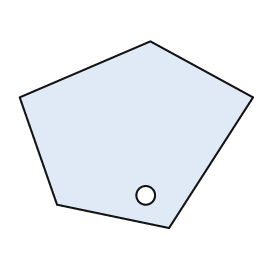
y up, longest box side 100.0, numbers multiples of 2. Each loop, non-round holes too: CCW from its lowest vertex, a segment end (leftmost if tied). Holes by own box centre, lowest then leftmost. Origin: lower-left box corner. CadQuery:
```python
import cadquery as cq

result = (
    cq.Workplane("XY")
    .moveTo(64.0, 0.0)
    .lineTo(100.0, 56.0)
    .lineTo(56.0, 80.0)
    .lineTo(0.0, 56.0)
    .lineTo(16.0, 10.0)
    .close()
    .moveTo(54.0, 14.0)
    .circle(4.0)
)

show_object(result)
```